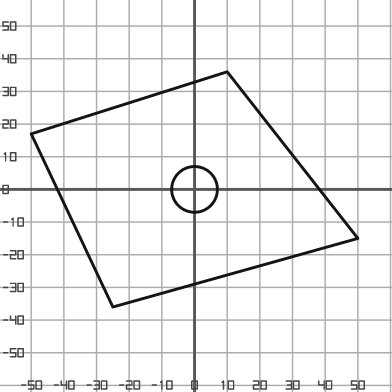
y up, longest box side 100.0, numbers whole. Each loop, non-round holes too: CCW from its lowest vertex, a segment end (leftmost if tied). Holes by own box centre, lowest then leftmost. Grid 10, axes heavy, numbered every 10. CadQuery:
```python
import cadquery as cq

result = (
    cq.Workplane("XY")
    .moveTo(-25.0, -36.0)
    .lineTo(50.0, -15.0)
    .lineTo(10.0, 36.0)
    .lineTo(-50.0, 17.0)
    .close()
    .moveTo(0.0, 0.0)
    .circle(7.0)
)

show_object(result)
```